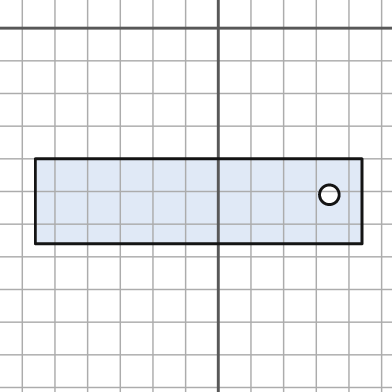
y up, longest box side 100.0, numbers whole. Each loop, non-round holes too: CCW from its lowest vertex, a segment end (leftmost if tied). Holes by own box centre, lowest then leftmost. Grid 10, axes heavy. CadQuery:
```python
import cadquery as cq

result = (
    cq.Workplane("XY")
    .moveTo(-56.0, -66.0)
    .lineTo(44.0, -66.0)
    .lineTo(44.0, -40.0)
    .lineTo(-56.0, -40.0)
    .close()
    .moveTo(34.0, -51.0)
    .circle(3.0)
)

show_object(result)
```